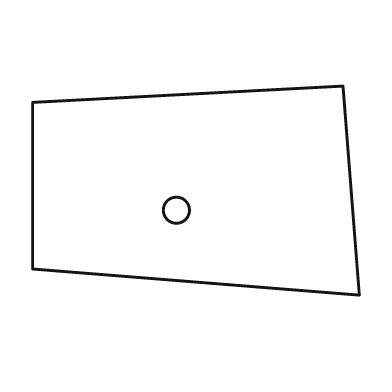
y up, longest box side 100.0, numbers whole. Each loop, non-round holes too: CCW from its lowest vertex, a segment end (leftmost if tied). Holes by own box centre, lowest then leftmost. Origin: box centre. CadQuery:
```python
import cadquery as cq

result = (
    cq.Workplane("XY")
    .moveTo(50.0, -32.0)
    .lineTo(45.0, 32.0)
    .lineTo(-50.0, 27.0)
    .lineTo(-50.0, -24.0)
    .close()
    .moveTo(-6.0, -6.0)
    .circle(4.0)
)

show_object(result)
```